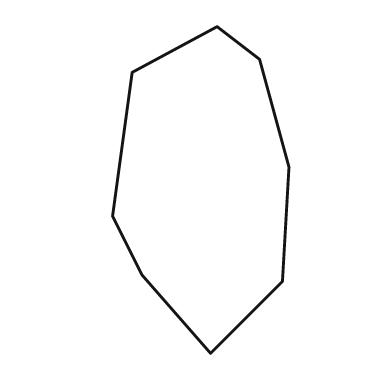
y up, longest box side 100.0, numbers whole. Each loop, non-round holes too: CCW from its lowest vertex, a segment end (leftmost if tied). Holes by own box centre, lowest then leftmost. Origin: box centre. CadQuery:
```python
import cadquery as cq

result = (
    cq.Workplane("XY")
    .moveTo(3.0, -50.0)
    .lineTo(25.0, -28.0)
    .lineTo(27.0, 7.0)
    .lineTo(18.0, 40.0)
    .lineTo(5.0, 50.0)
    .lineTo(-21.0, 36.0)
    .lineTo(-27.0, -8.0)
    .lineTo(-18.0, -26.0)
    .close()
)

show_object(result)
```